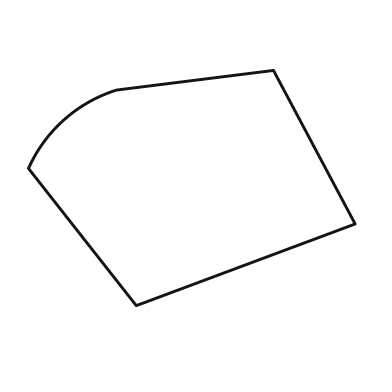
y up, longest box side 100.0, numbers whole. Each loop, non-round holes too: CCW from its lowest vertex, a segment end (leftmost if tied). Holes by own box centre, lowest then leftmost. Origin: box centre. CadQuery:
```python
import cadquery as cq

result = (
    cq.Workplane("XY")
    .moveTo(-17.0, -36.0)
    .lineTo(50.0, -11.0)
    .lineTo(25.0, 36.0)
    .lineTo(-23.0, 30.0)
    .threePointArc((-39.0, 21.0), (-50.0, 6.0))
    .close()
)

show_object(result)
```